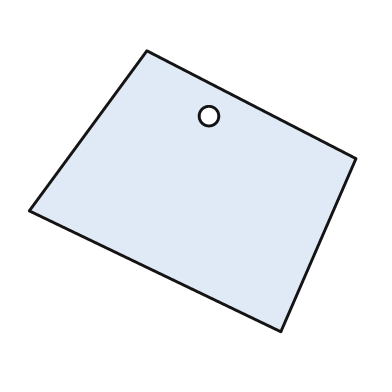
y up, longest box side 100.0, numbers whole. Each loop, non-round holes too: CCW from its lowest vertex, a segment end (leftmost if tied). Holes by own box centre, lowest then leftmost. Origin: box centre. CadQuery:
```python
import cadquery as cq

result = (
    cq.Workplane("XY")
    .moveTo(27.0, -43.0)
    .lineTo(50.0, 10.0)
    .lineTo(-14.0, 43.0)
    .lineTo(-50.0, -6.0)
    .close()
    .moveTo(5.0, 23.0)
    .circle(3.0)
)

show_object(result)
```